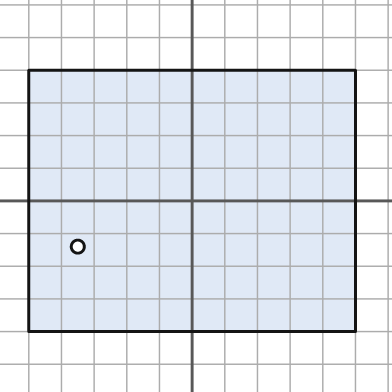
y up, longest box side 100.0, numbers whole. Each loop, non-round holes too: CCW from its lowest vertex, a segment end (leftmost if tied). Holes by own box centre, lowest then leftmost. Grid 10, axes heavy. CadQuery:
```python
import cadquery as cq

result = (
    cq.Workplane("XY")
    .moveTo(-50.0, -40.0)
    .lineTo(50.0, -40.0)
    .lineTo(50.0, 40.0)
    .lineTo(-50.0, 40.0)
    .close()
    .moveTo(-35.0, -14.0)
    .circle(2.0)
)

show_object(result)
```